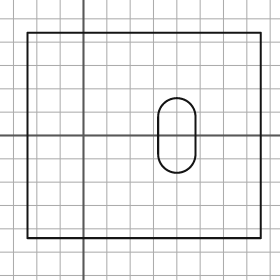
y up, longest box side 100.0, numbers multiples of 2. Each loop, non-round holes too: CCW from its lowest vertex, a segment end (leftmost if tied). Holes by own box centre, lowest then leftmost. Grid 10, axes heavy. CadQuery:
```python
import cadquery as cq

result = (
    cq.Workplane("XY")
    .moveTo(-24.0, -44.0)
    .lineTo(76.0, -44.0)
    .lineTo(76.0, 44.0)
    .lineTo(-24.0, 44.0)
    .close()
    .moveTo(32.0, -8.0)
    .threePointArc((40.0, -16.0), (48.0, -8.0))
    .lineTo(48.0, 8.0)
    .threePointArc((40.0, 16.0), (32.0, 8.0))
    .close()
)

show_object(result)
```